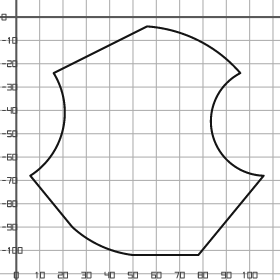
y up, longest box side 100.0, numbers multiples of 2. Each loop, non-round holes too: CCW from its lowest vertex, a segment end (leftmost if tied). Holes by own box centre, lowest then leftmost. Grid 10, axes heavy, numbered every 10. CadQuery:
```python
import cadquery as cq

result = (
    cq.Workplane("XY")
    .moveTo(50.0, -102.0)
    .lineTo(78.0, -102.0)
    .lineTo(106.0, -68.0)
    .threePointArc((84.0, -50.0), (96.0, -24.0))
    .threePointArc((78.0, -10.0), (56.0, -4.0))
    .lineTo(16.0, -24.0)
    .threePointArc((20.0, -48.0), (6.0, -68.0))
    .lineTo(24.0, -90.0)
    .threePointArc((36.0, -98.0), (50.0, -102.0))
    .close()
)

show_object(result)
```